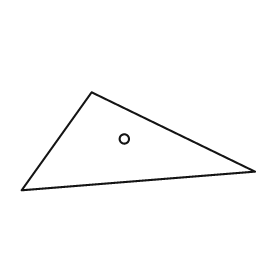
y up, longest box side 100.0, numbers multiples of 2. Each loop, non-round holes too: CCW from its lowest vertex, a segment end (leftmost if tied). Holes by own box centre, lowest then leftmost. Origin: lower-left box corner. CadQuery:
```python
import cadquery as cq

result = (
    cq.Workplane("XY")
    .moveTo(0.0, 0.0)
    .lineTo(100.0, 8.0)
    .lineTo(30.0, 42.0)
    .close()
    .moveTo(44.0, 22.0)
    .circle(2.0)
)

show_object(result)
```